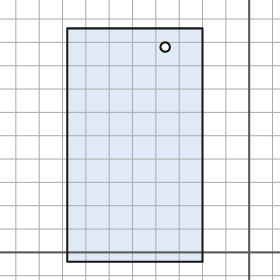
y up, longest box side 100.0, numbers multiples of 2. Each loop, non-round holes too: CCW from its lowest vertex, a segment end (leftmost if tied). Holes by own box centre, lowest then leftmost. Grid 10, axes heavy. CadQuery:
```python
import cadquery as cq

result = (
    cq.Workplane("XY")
    .moveTo(-78.0, -4.0)
    .lineTo(-20.0, -4.0)
    .lineTo(-20.0, 96.0)
    .lineTo(-78.0, 96.0)
    .close()
    .moveTo(-36.0, 88.0)
    .circle(2.0)
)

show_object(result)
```